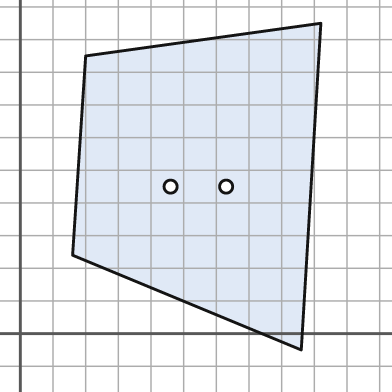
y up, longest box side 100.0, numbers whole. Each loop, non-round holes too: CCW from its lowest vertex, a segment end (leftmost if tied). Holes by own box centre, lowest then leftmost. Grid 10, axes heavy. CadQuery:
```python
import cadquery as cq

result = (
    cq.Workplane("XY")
    .moveTo(86.0, -5.0)
    .lineTo(92.0, 95.0)
    .lineTo(20.0, 85.0)
    .lineTo(16.0, 24.0)
    .close()
    .moveTo(46.0, 45.0)
    .circle(2.0)
    .moveTo(63.0, 45.0)
    .circle(2.0)
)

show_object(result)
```